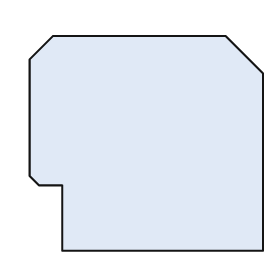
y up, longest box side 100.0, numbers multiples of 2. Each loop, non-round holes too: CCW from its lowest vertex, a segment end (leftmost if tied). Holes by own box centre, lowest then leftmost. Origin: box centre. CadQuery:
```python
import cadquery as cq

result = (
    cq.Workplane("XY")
    .moveTo(-36.0, -46.0)
    .lineTo(50.0, -46.0)
    .lineTo(50.0, 30.0)
    .lineTo(34.0, 46.0)
    .lineTo(-40.0, 46.0)
    .lineTo(-50.0, 36.0)
    .lineTo(-50.0, -14.0)
    .lineTo(-46.0, -18.0)
    .lineTo(-36.0, -18.0)
    .close()
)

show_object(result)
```